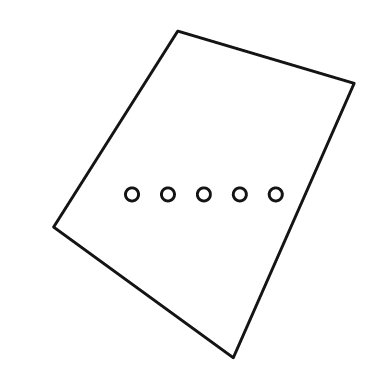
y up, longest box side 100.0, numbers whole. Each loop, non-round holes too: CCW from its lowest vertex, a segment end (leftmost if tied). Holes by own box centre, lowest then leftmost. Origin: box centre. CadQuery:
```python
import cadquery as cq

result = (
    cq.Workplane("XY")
    .moveTo(9.0, -50.0)
    .lineTo(46.0, 34.0)
    .lineTo(-8.0, 50.0)
    .lineTo(-46.0, -10.0)
    .close()
    .moveTo(-22.0, 0.0)
    .circle(2.0)
    .moveTo(-11.0, 0.0)
    .circle(2.0)
    .moveTo(0.0, 0.0)
    .circle(2.0)
    .moveTo(11.0, 0.0)
    .circle(2.0)
    .moveTo(22.0, 0.0)
    .circle(2.0)
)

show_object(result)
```